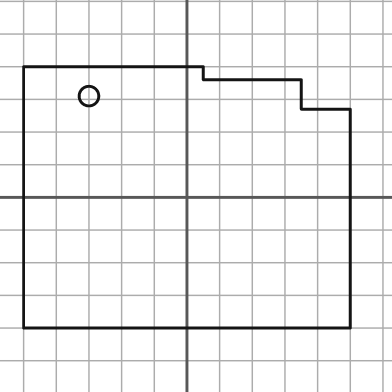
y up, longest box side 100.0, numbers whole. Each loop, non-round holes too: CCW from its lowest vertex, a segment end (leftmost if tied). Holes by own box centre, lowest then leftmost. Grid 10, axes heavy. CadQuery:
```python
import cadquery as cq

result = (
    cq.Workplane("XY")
    .moveTo(-50.0, -40.0)
    .lineTo(50.0, -40.0)
    .lineTo(50.0, 27.0)
    .lineTo(35.0, 27.0)
    .lineTo(35.0, 36.0)
    .lineTo(5.0, 36.0)
    .lineTo(5.0, 40.0)
    .lineTo(-50.0, 40.0)
    .close()
    .moveTo(-30.0, 31.0)
    .circle(3.0)
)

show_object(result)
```